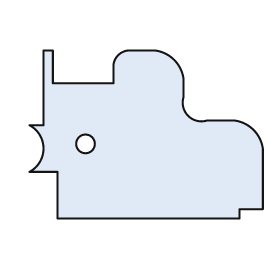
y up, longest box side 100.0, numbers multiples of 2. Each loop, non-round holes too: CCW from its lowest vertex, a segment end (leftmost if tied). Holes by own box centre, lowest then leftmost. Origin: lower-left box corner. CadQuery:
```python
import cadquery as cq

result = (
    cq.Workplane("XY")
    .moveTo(12.0, 0.0)
    .lineTo(90.0, 0.0)
    .lineTo(90.0, 4.0)
    .lineTo(100.0, 4.0)
    .lineTo(100.0, 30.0)
    .threePointArc((96.0, 38.0), (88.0, 42.0))
    .lineTo(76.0, 42.0)
    .threePointArc((68.0, 44.0), (66.0, 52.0))
    .lineTo(66.0, 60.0)
    .threePointArc((62.0, 68.0), (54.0, 72.0))
    .lineTo(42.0, 72.0)
    .threePointArc((38.0, 70.0), (36.0, 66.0))
    .lineTo(36.0, 58.0)
    .lineTo(10.0, 58.0)
    .lineTo(10.0, 72.0)
    .lineTo(6.0, 72.0)
    .lineTo(6.0, 40.0)
    .lineTo(0.0, 40.0)
    .threePointArc((6.0, 30.0), (0.0, 20.0))
    .lineTo(12.0, 20.0)
    .close()
    .moveTo(24.0, 32.0)
    .circle(4.0)
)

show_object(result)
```